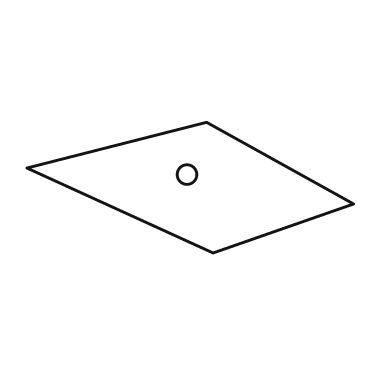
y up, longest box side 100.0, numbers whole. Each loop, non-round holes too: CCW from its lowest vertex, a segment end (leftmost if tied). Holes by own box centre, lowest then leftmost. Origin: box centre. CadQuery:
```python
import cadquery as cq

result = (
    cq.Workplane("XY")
    .moveTo(7.0, -20.0)
    .lineTo(50.0, -5.0)
    .lineTo(5.0, 20.0)
    .lineTo(-50.0, 6.0)
    .close()
    .moveTo(-1.0, 4.0)
    .circle(3.0)
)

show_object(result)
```